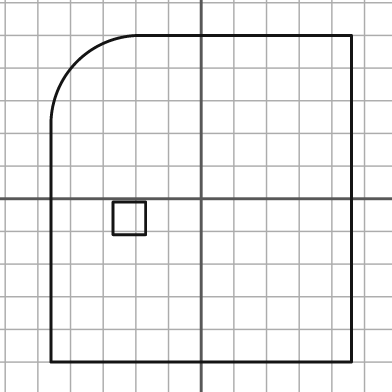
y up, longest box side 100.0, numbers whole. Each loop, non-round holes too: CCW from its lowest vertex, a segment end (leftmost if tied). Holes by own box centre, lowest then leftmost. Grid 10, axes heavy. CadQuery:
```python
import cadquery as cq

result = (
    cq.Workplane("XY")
    .moveTo(-46.0, -50.0)
    .lineTo(46.0, -50.0)
    .lineTo(46.0, 50.0)
    .lineTo(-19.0, 50.0)
    .threePointArc((-38.0, 42.0), (-46.0, 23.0))
    .close()
    .moveTo(-27.0, -11.0)
    .lineTo(-17.0, -11.0)
    .lineTo(-17.0, -1.0)
    .lineTo(-27.0, -1.0)
    .close()
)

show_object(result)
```